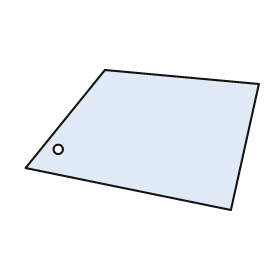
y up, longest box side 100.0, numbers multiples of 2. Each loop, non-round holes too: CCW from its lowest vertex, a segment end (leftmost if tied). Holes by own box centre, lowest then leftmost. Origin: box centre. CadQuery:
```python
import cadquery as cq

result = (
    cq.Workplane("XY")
    .moveTo(38.0, -30.0)
    .lineTo(50.0, 24.0)
    .lineTo(-16.0, 30.0)
    .lineTo(-50.0, -12.0)
    .close()
    .moveTo(-36.0, -4.0)
    .circle(2.0)
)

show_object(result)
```